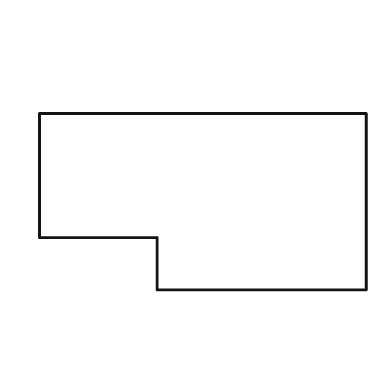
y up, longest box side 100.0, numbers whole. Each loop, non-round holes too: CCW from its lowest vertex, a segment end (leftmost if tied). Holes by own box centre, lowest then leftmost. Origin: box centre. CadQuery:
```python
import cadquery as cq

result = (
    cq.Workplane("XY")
    .moveTo(-14.0, -27.0)
    .lineTo(50.0, -27.0)
    .lineTo(50.0, 27.0)
    .lineTo(-50.0, 27.0)
    .lineTo(-50.0, -11.0)
    .lineTo(-14.0, -11.0)
    .close()
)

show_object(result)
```